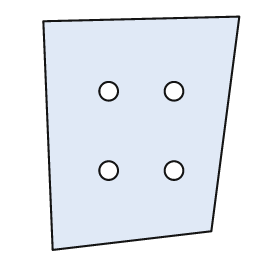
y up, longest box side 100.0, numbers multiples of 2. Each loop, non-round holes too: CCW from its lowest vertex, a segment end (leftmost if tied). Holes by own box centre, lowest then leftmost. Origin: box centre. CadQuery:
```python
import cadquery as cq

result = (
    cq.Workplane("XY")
    .moveTo(-38.0, -50.0)
    .lineTo(30.0, -42.0)
    .lineTo(42.0, 50.0)
    .lineTo(-42.0, 48.0)
    .close()
    .moveTo(-14.0, -16.0)
    .circle(4.0)
    .moveTo(14.0, -16.0)
    .circle(4.0)
    .moveTo(-14.0, 18.0)
    .circle(4.0)
    .moveTo(14.0, 18.0)
    .circle(4.0)
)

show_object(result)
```